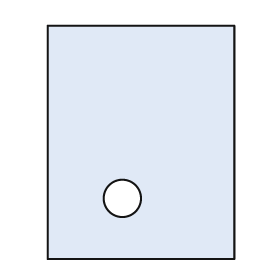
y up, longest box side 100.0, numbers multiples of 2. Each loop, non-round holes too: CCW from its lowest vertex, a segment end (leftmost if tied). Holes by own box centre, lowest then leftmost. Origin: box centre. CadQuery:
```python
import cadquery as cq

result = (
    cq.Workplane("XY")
    .moveTo(-40.0, -50.0)
    .lineTo(40.0, -50.0)
    .lineTo(40.0, 50.0)
    .lineTo(-40.0, 50.0)
    .close()
    .moveTo(-8.0, -24.0)
    .circle(8.0)
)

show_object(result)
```